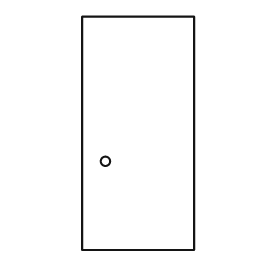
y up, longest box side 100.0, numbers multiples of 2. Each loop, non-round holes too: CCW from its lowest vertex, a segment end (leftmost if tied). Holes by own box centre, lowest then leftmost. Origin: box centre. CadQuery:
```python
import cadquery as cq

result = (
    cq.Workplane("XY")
    .moveTo(-24.0, -50.0)
    .lineTo(24.0, -50.0)
    .lineTo(24.0, 50.0)
    .lineTo(-24.0, 50.0)
    .close()
    .moveTo(-14.0, -12.0)
    .circle(2.0)
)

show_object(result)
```